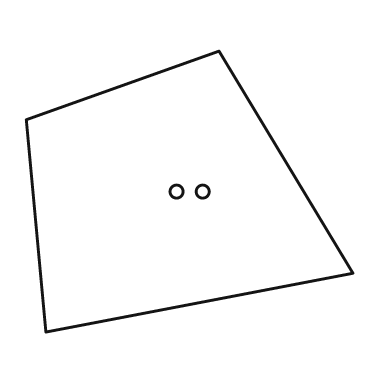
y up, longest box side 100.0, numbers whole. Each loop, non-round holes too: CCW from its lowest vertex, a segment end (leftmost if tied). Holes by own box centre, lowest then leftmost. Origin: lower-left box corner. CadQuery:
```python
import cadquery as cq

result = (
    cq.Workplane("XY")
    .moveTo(6.0, 0.0)
    .lineTo(100.0, 18.0)
    .lineTo(59.0, 86.0)
    .lineTo(0.0, 65.0)
    .close()
    .moveTo(46.0, 43.0)
    .circle(2.0)
    .moveTo(54.0, 43.0)
    .circle(2.0)
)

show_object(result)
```